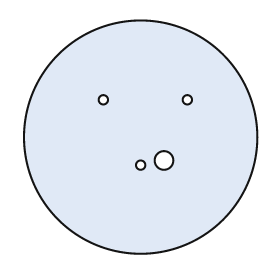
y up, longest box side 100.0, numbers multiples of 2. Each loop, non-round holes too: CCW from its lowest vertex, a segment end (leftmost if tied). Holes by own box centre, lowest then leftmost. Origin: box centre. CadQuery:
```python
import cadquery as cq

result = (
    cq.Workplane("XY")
    .moveTo(0.0, 0.0)
    .circle(50.0)
    .moveTo(0.0, -12.0)
    .circle(2.0)
    .moveTo(10.0, -10.0)
    .circle(4.0)
    .moveTo(-16.0, 16.0)
    .circle(2.0)
    .moveTo(20.0, 16.0)
    .circle(2.0)
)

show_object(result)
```